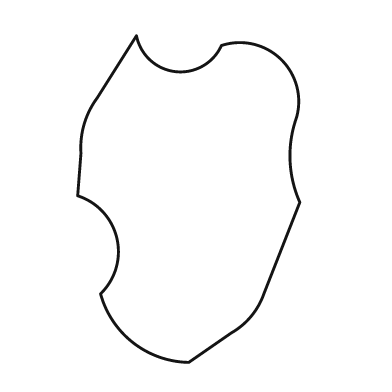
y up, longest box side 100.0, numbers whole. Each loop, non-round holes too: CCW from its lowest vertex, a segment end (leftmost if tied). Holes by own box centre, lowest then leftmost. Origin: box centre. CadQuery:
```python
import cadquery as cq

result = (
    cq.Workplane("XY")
    .moveTo(0.0, -50.0)
    .lineTo(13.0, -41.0)
    .threePointArc((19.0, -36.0), (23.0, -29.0))
    .lineTo(34.0, -1.0)
    .threePointArc((31.0, 12.0), (33.0, 25.0))
    .threePointArc((28.0, 43.0), (10.0, 47.0))
    .threePointArc((-4.0, 39.0), (-16.0, 50.0))
    .lineTo(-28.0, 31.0)
    .threePointArc((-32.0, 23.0), (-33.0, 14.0))
    .lineTo(-34.0, 1.0)
    .threePointArc((-22.0, -12.0), (-27.0, -29.0))
    .threePointArc((-17.0, -44.0), (0.0, -50.0))
    .close()
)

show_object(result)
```